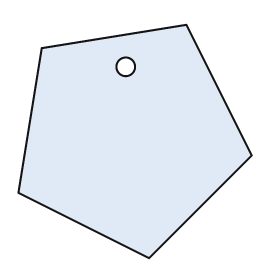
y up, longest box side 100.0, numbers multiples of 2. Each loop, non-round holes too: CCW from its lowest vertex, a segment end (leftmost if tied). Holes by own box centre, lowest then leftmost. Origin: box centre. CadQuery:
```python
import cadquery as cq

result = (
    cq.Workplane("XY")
    .moveTo(6.0, -50.0)
    .lineTo(50.0, -6.0)
    .lineTo(22.0, 50.0)
    .lineTo(-40.0, 40.0)
    .lineTo(-50.0, -22.0)
    .close()
    .moveTo(-4.0, 32.0)
    .circle(4.0)
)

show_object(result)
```